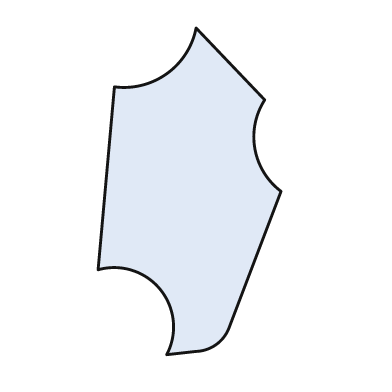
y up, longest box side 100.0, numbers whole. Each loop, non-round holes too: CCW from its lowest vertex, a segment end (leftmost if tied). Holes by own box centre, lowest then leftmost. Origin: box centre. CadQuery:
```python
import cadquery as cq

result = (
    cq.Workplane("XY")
    .moveTo(-7.0, -50.0)
    .lineTo(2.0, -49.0)
    .threePointArc((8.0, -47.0), (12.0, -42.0))
    .lineTo(28.0, 0.0)
    .threePointArc((20.0, 13.0), (23.0, 28.0))
    .lineTo(2.0, 50.0)
    .threePointArc((-7.0, 36.0), (-23.0, 32.0))
    .lineTo(-28.0, -24.0)
    .threePointArc((-9.0, -30.0), (-7.0, -50.0))
    .close()
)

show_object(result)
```